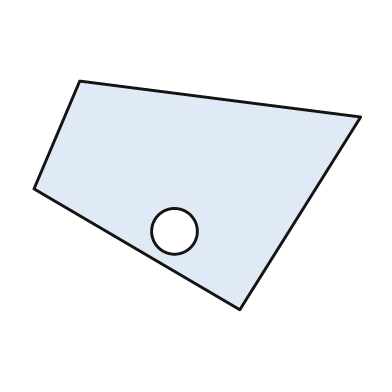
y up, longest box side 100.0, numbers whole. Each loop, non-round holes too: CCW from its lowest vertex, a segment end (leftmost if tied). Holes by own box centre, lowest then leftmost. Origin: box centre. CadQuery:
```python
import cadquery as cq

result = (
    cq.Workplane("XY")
    .moveTo(13.0, -35.0)
    .lineTo(50.0, 24.0)
    .lineTo(-36.0, 35.0)
    .lineTo(-50.0, 2.0)
    .close()
    .moveTo(-7.0, -11.0)
    .circle(7.0)
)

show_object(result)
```